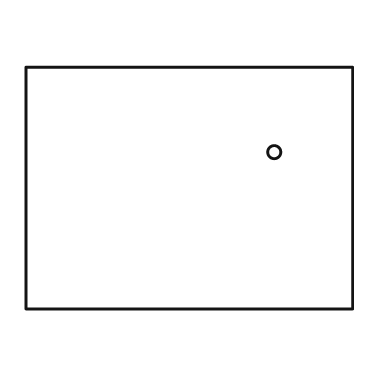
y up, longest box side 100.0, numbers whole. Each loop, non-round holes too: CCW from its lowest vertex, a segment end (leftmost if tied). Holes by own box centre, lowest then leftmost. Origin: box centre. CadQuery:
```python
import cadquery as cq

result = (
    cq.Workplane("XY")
    .moveTo(-50.0, -37.0)
    .lineTo(50.0, -37.0)
    .lineTo(50.0, 37.0)
    .lineTo(-50.0, 37.0)
    .close()
    .moveTo(26.0, 11.0)
    .circle(2.0)
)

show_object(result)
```